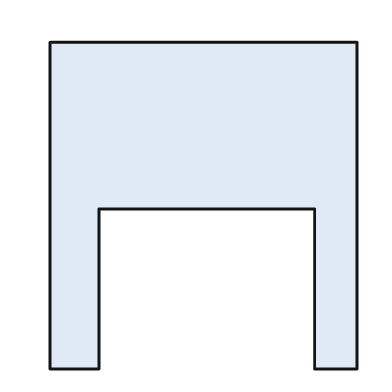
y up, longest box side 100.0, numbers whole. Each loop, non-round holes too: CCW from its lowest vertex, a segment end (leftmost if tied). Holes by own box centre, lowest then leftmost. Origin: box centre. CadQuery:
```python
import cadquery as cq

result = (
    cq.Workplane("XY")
    .moveTo(-47.0, -50.0)
    .lineTo(-32.0, -50.0)
    .lineTo(-32.0, -1.0)
    .lineTo(34.0, -1.0)
    .lineTo(34.0, -50.0)
    .lineTo(47.0, -50.0)
    .lineTo(47.0, 50.0)
    .lineTo(-47.0, 50.0)
    .close()
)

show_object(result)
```